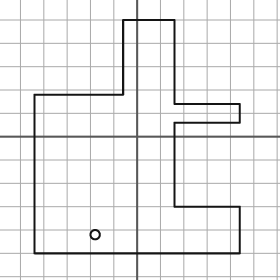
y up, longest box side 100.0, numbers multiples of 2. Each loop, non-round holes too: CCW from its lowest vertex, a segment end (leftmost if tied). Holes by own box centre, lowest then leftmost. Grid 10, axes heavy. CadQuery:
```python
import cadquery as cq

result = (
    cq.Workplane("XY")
    .moveTo(-44.0, -50.0)
    .lineTo(44.0, -50.0)
    .lineTo(44.0, -30.0)
    .lineTo(16.0, -30.0)
    .lineTo(16.0, 6.0)
    .lineTo(44.0, 6.0)
    .lineTo(44.0, 14.0)
    .lineTo(16.0, 14.0)
    .lineTo(16.0, 50.0)
    .lineTo(-6.0, 50.0)
    .lineTo(-6.0, 18.0)
    .lineTo(-44.0, 18.0)
    .close()
    .moveTo(-18.0, -42.0)
    .circle(2.0)
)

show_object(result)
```